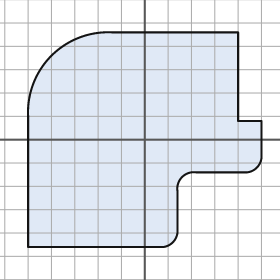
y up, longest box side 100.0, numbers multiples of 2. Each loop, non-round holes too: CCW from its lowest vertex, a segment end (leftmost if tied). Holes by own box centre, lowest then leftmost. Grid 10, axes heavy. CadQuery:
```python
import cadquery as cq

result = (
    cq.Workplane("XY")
    .moveTo(-50.0, -46.0)
    .lineTo(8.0, -46.0)
    .threePointArc((12.0, -44.0), (14.0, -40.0))
    .lineTo(14.0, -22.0)
    .threePointArc((16.0, -16.0), (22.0, -14.0))
    .lineTo(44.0, -14.0)
    .threePointArc((48.0, -12.0), (50.0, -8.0))
    .lineTo(50.0, 8.0)
    .lineTo(40.0, 8.0)
    .lineTo(40.0, 46.0)
    .lineTo(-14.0, 46.0)
    .threePointArc((-40.0, 36.0), (-50.0, 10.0))
    .close()
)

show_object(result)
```